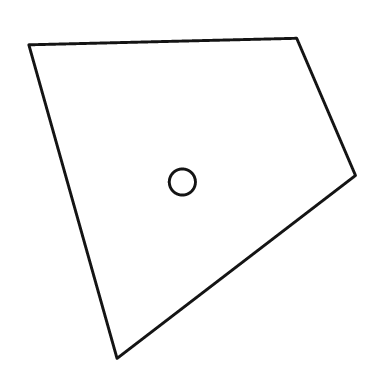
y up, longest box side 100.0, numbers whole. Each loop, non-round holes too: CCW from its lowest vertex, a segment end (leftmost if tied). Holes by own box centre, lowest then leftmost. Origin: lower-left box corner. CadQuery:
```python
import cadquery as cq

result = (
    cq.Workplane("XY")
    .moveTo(27.0, 0.0)
    .lineTo(100.0, 56.0)
    .lineTo(82.0, 98.0)
    .lineTo(0.0, 96.0)
    .close()
    .moveTo(47.0, 54.0)
    .circle(4.0)
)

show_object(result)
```